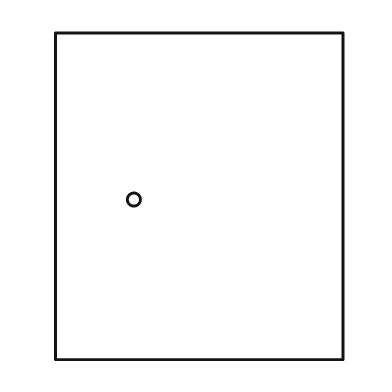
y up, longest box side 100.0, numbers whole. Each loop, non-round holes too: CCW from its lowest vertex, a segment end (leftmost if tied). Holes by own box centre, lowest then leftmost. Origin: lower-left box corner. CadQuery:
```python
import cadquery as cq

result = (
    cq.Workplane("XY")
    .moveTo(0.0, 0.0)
    .lineTo(88.0, 0.0)
    .lineTo(88.0, 100.0)
    .lineTo(0.0, 100.0)
    .close()
    .moveTo(24.0, 49.0)
    .circle(2.0)
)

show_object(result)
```